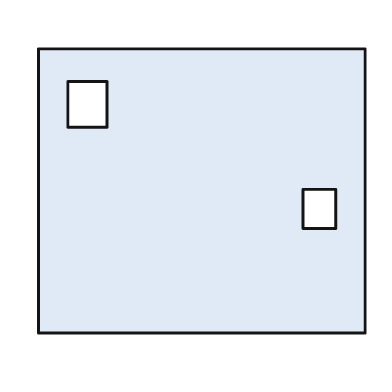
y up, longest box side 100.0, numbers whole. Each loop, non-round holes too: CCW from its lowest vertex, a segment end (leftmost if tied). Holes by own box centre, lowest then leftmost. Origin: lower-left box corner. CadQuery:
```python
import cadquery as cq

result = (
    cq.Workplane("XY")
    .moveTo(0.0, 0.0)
    .lineTo(100.0, 0.0)
    .lineTo(100.0, 87.0)
    .lineTo(0.0, 87.0)
    .close()
    .moveTo(81.0, 32.0)
    .lineTo(91.0, 32.0)
    .lineTo(91.0, 44.0)
    .lineTo(81.0, 44.0)
    .close()
    .moveTo(9.0, 63.0)
    .lineTo(21.0, 63.0)
    .lineTo(21.0, 77.0)
    .lineTo(9.0, 77.0)
    .close()
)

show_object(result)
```